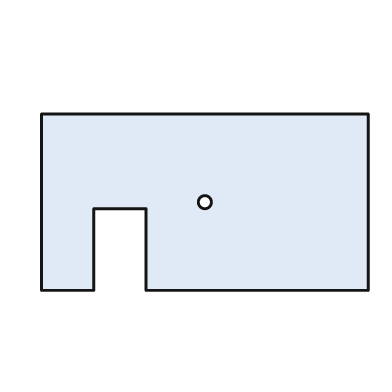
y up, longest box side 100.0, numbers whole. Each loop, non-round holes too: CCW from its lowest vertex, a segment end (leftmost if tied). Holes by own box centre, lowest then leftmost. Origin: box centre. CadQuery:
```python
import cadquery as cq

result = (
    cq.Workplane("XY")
    .moveTo(-50.0, -27.0)
    .lineTo(-34.0, -27.0)
    .lineTo(-34.0, -2.0)
    .lineTo(-18.0, -2.0)
    .lineTo(-18.0, -27.0)
    .lineTo(50.0, -27.0)
    .lineTo(50.0, 27.0)
    .lineTo(-50.0, 27.0)
    .close()
    .moveTo(0.0, 0.0)
    .circle(2.0)
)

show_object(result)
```